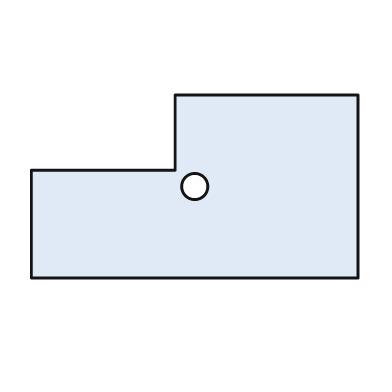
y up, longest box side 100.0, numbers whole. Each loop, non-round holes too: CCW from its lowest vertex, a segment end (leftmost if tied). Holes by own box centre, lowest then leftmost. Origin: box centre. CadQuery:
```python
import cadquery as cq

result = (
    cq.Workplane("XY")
    .moveTo(-50.0, -28.0)
    .lineTo(50.0, -28.0)
    .lineTo(50.0, 28.0)
    .lineTo(-6.0, 28.0)
    .lineTo(-6.0, 5.0)
    .lineTo(-50.0, 5.0)
    .close()
    .moveTo(0.0, 0.0)
    .circle(4.0)
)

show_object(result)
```